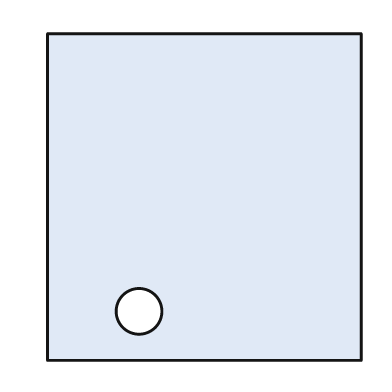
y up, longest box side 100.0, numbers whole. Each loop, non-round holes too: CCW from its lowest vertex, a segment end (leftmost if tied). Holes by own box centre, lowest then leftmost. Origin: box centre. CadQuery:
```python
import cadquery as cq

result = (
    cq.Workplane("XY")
    .moveTo(-48.0, -50.0)
    .lineTo(48.0, -50.0)
    .lineTo(48.0, 50.0)
    .lineTo(-48.0, 50.0)
    .close()
    .moveTo(-20.0, -35.0)
    .circle(7.0)
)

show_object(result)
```